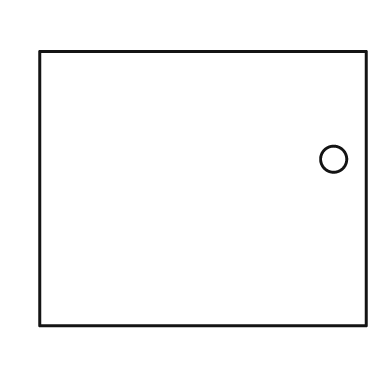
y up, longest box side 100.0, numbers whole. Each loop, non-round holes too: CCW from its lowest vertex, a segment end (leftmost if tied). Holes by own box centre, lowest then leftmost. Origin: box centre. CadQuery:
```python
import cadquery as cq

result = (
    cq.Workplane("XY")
    .moveTo(-50.0, -42.0)
    .lineTo(50.0, -42.0)
    .lineTo(50.0, 42.0)
    .lineTo(-50.0, 42.0)
    .close()
    .moveTo(40.0, 9.0)
    .circle(4.0)
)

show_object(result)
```